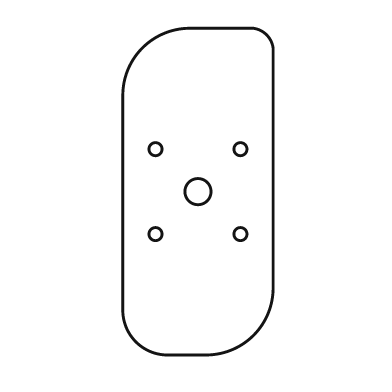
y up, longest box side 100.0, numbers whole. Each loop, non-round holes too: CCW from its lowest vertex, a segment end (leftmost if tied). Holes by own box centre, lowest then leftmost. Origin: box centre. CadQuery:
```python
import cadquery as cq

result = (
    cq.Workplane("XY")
    .moveTo(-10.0, -50.0)
    .lineTo(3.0, -50.0)
    .threePointArc((17.0, -44.0), (23.0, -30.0))
    .lineTo(23.0, 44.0)
    .threePointArc((21.0, 48.0), (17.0, 50.0))
    .lineTo(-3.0, 50.0)
    .threePointArc((-17.0, 44.0), (-23.0, 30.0))
    .lineTo(-23.0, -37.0)
    .threePointArc((-19.0, -46.0), (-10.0, -50.0))
    .close()
    .moveTo(-13.0, -13.0)
    .circle(2.0)
    .moveTo(13.0, -13.0)
    .circle(2.0)
    .moveTo(0.0, 0.0)
    .circle(4.0)
    .moveTo(-13.0, 13.0)
    .circle(2.0)
    .moveTo(13.0, 13.0)
    .circle(2.0)
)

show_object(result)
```